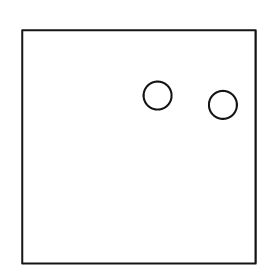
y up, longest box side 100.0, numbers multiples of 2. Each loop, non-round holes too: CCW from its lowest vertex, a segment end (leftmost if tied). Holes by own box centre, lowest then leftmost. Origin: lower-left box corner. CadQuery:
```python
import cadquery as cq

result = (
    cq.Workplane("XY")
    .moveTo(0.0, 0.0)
    .lineTo(100.0, 0.0)
    .lineTo(100.0, 100.0)
    .lineTo(0.0, 100.0)
    .close()
    .moveTo(86.0, 68.0)
    .circle(6.0)
    .moveTo(58.0, 72.0)
    .circle(6.0)
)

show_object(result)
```